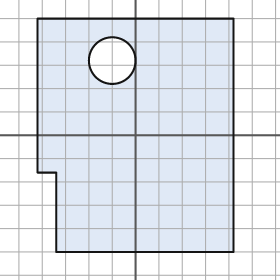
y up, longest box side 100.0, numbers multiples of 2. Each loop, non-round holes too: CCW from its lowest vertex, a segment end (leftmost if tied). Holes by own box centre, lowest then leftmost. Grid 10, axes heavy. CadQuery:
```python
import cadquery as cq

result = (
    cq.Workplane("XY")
    .moveTo(-34.0, -50.0)
    .lineTo(42.0, -50.0)
    .lineTo(42.0, 50.0)
    .lineTo(-42.0, 50.0)
    .lineTo(-42.0, -16.0)
    .lineTo(-34.0, -16.0)
    .close()
    .moveTo(-10.0, 32.0)
    .circle(10.0)
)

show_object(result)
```